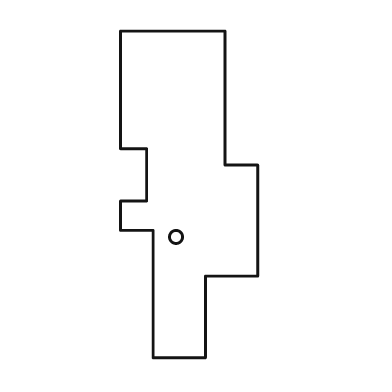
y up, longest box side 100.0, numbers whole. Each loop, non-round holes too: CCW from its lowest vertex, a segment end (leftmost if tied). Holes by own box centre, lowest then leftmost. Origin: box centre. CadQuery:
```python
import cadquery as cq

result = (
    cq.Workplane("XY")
    .moveTo(-11.0, -50.0)
    .lineTo(5.0, -50.0)
    .lineTo(5.0, -25.0)
    .lineTo(21.0, -25.0)
    .lineTo(21.0, 9.0)
    .lineTo(11.0, 9.0)
    .lineTo(11.0, 50.0)
    .lineTo(-21.0, 50.0)
    .lineTo(-21.0, 14.0)
    .lineTo(-13.0, 14.0)
    .lineTo(-13.0, -2.0)
    .lineTo(-21.0, -2.0)
    .lineTo(-21.0, -11.0)
    .lineTo(-11.0, -11.0)
    .close()
    .moveTo(-4.0, -13.0)
    .circle(2.0)
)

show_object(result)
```